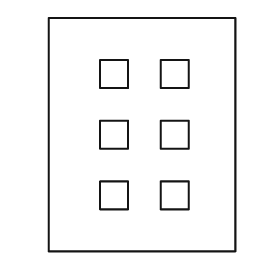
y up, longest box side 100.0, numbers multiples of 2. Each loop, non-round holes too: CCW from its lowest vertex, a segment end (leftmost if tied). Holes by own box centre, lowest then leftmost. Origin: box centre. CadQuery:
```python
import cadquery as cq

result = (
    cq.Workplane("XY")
    .moveTo(-40.0, -50.0)
    .lineTo(40.0, -50.0)
    .lineTo(40.0, 50.0)
    .lineTo(-40.0, 50.0)
    .close()
    .moveTo(-18.0, -32.0)
    .lineTo(-6.0, -32.0)
    .lineTo(-6.0, -20.0)
    .lineTo(-18.0, -20.0)
    .close()
    .moveTo(8.0, -32.0)
    .lineTo(20.0, -32.0)
    .lineTo(20.0, -20.0)
    .lineTo(8.0, -20.0)
    .close()
    .moveTo(-18.0, -6.0)
    .lineTo(-6.0, -6.0)
    .lineTo(-6.0, 6.0)
    .lineTo(-18.0, 6.0)
    .close()
    .moveTo(8.0, -6.0)
    .lineTo(20.0, -6.0)
    .lineTo(20.0, 6.0)
    .lineTo(8.0, 6.0)
    .close()
    .moveTo(-18.0, 20.0)
    .lineTo(-6.0, 20.0)
    .lineTo(-6.0, 32.0)
    .lineTo(-18.0, 32.0)
    .close()
    .moveTo(8.0, 20.0)
    .lineTo(20.0, 20.0)
    .lineTo(20.0, 32.0)
    .lineTo(8.0, 32.0)
    .close()
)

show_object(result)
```